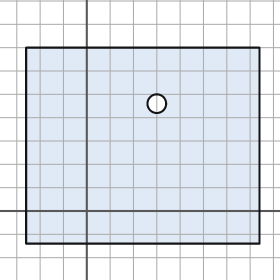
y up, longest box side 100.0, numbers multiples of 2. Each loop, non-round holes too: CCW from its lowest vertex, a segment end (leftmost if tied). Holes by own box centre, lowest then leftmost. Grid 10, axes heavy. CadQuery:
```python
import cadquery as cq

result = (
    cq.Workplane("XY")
    .moveTo(-26.0, -14.0)
    .lineTo(74.0, -14.0)
    .lineTo(74.0, 70.0)
    .lineTo(-26.0, 70.0)
    .close()
    .moveTo(30.0, 46.0)
    .circle(4.0)
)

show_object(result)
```